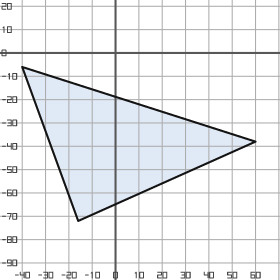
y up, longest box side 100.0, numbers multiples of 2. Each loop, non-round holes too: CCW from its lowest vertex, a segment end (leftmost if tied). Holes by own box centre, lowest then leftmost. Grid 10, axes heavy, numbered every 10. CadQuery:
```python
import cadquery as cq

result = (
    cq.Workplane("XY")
    .moveTo(-16.0, -72.0)
    .lineTo(60.0, -38.0)
    .lineTo(-40.0, -6.0)
    .close()
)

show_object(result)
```